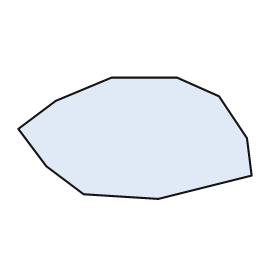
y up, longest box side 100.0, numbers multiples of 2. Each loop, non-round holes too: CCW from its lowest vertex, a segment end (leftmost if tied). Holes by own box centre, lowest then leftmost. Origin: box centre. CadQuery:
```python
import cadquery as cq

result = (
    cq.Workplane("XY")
    .moveTo(10.0, -26.0)
    .lineTo(50.0, -16.0)
    .lineTo(48.0, 0.0)
    .lineTo(36.0, 18.0)
    .lineTo(18.0, 26.0)
    .lineTo(-10.0, 26.0)
    .lineTo(-34.0, 16.0)
    .lineTo(-50.0, 4.0)
    .lineTo(-38.0, -12.0)
    .lineTo(-22.0, -24.0)
    .close()
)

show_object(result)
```